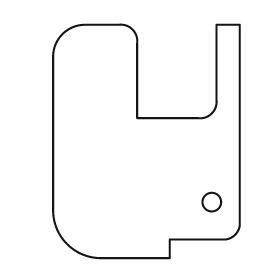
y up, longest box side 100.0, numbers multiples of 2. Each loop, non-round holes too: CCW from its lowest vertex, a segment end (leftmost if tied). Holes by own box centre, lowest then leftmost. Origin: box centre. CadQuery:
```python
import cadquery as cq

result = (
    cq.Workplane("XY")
    .moveTo(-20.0, -50.0)
    .lineTo(10.0, -50.0)
    .lineTo(10.0, -42.0)
    .lineTo(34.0, -42.0)
    .threePointArc((38.0, -40.0), (40.0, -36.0))
    .lineTo(40.0, 50.0)
    .lineTo(30.0, 50.0)
    .lineTo(30.0, 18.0)
    .threePointArc((28.0, 12.0), (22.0, 10.0))
    .lineTo(-4.0, 10.0)
    .lineTo(-4.0, 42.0)
    .threePointArc((-6.0, 48.0), (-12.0, 50.0))
    .lineTo(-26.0, 50.0)
    .threePointArc((-36.0, 46.0), (-40.0, 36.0))
    .lineTo(-40.0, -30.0)
    .threePointArc((-34.0, -44.0), (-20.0, -50.0))
    .close()
    .moveTo(28.0, -26.0)
    .circle(4.0)
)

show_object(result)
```